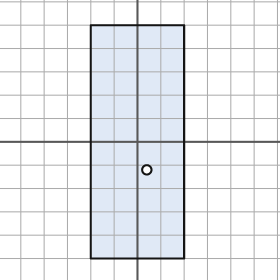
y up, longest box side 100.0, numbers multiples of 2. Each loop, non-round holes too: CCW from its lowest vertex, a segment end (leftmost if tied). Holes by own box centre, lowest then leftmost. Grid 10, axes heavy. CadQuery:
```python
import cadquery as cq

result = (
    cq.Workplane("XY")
    .moveTo(-20.0, -50.0)
    .lineTo(20.0, -50.0)
    .lineTo(20.0, 50.0)
    .lineTo(-20.0, 50.0)
    .close()
    .moveTo(4.0, -12.0)
    .circle(2.0)
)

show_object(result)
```